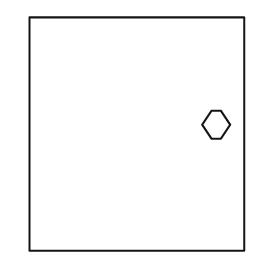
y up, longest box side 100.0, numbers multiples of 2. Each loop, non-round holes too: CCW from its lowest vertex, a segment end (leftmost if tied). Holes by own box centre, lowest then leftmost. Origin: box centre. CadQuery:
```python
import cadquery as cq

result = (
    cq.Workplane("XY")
    .moveTo(-46.0, -50.0)
    .lineTo(46.0, -50.0)
    .lineTo(46.0, 50.0)
    .lineTo(-46.0, 50.0)
    .close()
    .moveTo(32.0, -2.0)
    .lineTo(36.0, -2.0)
    .lineTo(40.0, 4.0)
    .lineTo(36.0, 10.0)
    .lineTo(32.0, 10.0)
    .lineTo(28.0, 4.0)
    .close()
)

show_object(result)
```